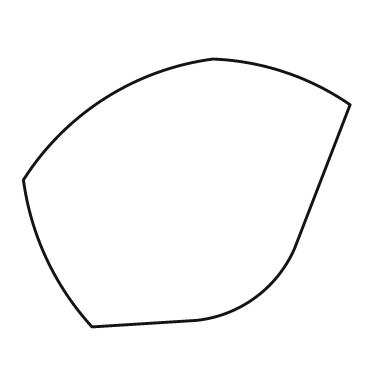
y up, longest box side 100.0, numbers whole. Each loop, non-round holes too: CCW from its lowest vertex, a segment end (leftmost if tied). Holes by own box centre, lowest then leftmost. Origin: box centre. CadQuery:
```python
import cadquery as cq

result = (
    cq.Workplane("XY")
    .moveTo(-29.0, -41.0)
    .lineTo(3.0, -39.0)
    .threePointArc((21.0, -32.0), (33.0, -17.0))
    .lineTo(50.0, 27.0)
    .threePointArc((30.0, 37.0), (8.0, 41.0))
    .threePointArc((-25.0, 29.0), (-50.0, 4.0))
    .threePointArc((-43.0, -20.0), (-29.0, -41.0))
    .close()
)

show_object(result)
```